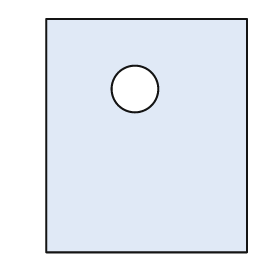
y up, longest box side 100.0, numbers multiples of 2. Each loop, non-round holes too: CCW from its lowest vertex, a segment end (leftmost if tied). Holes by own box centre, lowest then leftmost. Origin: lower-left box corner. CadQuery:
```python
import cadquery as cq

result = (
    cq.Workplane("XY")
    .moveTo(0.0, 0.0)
    .lineTo(86.0, 0.0)
    .lineTo(86.0, 100.0)
    .lineTo(0.0, 100.0)
    .close()
    .moveTo(38.0, 70.0)
    .circle(10.0)
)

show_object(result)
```